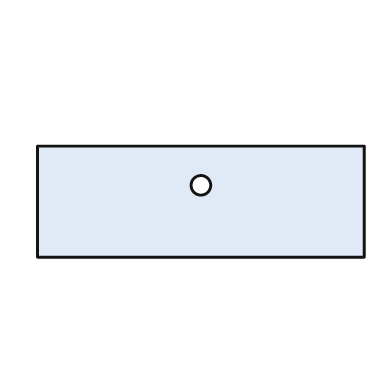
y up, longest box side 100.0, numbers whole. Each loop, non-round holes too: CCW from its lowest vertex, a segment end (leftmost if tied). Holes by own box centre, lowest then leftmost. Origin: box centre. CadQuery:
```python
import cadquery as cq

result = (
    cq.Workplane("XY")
    .moveTo(-50.0, -17.0)
    .lineTo(50.0, -17.0)
    .lineTo(50.0, 17.0)
    .lineTo(-50.0, 17.0)
    .close()
    .moveTo(0.0, 5.0)
    .circle(3.0)
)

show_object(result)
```